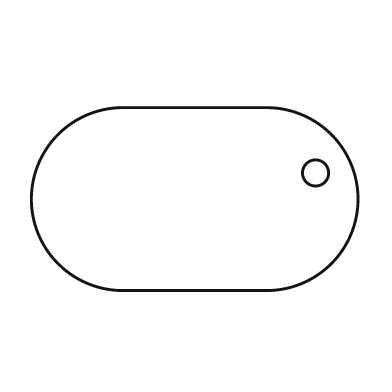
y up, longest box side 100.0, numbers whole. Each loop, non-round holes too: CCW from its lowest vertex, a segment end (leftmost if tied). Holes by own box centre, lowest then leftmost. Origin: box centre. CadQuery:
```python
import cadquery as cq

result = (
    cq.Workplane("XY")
    .moveTo(-22.0, -28.0)
    .lineTo(22.0, -28.0)
    .threePointArc((50.0, 0.0), (22.0, 28.0))
    .lineTo(-22.0, 28.0)
    .threePointArc((-50.0, 0.0), (-22.0, -28.0))
    .close()
    .moveTo(37.0, 8.0)
    .circle(4.0)
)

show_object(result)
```